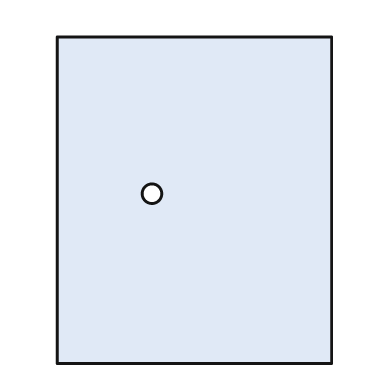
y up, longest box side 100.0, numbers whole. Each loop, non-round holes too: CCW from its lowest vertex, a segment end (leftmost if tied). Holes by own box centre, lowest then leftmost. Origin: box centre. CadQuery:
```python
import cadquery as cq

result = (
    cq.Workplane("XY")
    .moveTo(-42.0, -50.0)
    .lineTo(42.0, -50.0)
    .lineTo(42.0, 50.0)
    .lineTo(-42.0, 50.0)
    .close()
    .moveTo(-13.0, 2.0)
    .circle(3.0)
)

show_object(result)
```